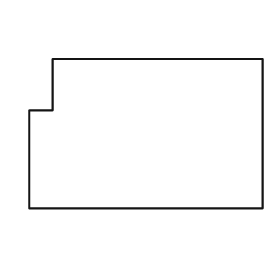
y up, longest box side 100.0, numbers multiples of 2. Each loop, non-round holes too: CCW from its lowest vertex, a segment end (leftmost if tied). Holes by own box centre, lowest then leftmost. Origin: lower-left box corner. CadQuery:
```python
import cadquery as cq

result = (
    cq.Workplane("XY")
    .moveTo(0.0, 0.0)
    .lineTo(100.0, 0.0)
    .lineTo(100.0, 64.0)
    .lineTo(10.0, 64.0)
    .lineTo(10.0, 42.0)
    .lineTo(0.0, 42.0)
    .close()
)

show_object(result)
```